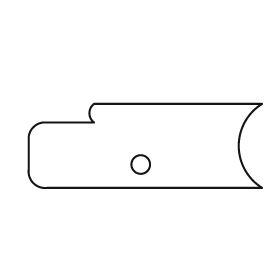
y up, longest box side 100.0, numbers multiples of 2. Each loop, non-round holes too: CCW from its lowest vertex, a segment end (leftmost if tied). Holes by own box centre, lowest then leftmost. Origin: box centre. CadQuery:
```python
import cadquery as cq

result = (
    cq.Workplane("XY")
    .moveTo(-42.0, -18.0)
    .lineTo(50.0, -18.0)
    .threePointArc((40.0, 0.0), (50.0, 18.0))
    .lineTo(-22.0, 18.0)
    .threePointArc((-24.0, 14.0), (-22.0, 10.0))
    .lineTo(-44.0, 10.0)
    .threePointArc((-48.0, 8.0), (-50.0, 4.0))
    .lineTo(-50.0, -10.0)
    .threePointArc((-48.0, -16.0), (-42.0, -18.0))
    .close()
    .moveTo(-2.0, -8.0)
    .circle(4.0)
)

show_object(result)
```